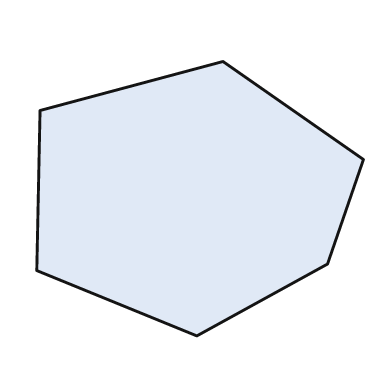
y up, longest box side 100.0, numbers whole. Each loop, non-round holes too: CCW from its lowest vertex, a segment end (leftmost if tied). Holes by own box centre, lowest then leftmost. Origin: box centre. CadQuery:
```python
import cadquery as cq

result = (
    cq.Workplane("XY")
    .moveTo(-1.0, -42.0)
    .lineTo(39.0, -20.0)
    .lineTo(50.0, 12.0)
    .lineTo(7.0, 42.0)
    .lineTo(-49.0, 27.0)
    .lineTo(-50.0, -22.0)
    .close()
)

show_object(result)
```